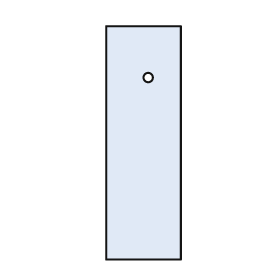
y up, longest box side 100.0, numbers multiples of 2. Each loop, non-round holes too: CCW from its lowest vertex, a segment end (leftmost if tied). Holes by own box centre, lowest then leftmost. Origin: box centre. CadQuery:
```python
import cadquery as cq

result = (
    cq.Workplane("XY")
    .moveTo(-16.0, -50.0)
    .lineTo(16.0, -50.0)
    .lineTo(16.0, 50.0)
    .lineTo(-16.0, 50.0)
    .close()
    .moveTo(2.0, 28.0)
    .circle(2.0)
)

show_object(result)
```